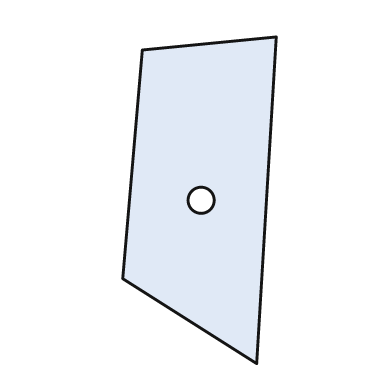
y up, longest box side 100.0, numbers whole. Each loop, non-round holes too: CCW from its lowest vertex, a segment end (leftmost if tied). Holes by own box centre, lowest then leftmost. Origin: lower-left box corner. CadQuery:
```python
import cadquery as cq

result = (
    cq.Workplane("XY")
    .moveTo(41.0, 0.0)
    .lineTo(47.0, 100.0)
    .lineTo(6.0, 96.0)
    .lineTo(0.0, 26.0)
    .close()
    .moveTo(24.0, 50.0)
    .circle(4.0)
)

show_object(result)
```